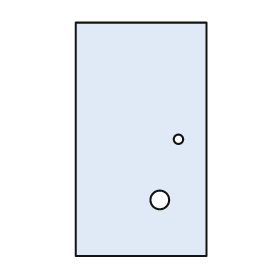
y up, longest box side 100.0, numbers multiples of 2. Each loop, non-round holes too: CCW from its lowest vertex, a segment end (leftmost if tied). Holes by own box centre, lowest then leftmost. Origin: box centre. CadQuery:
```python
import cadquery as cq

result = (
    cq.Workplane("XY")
    .moveTo(-28.0, -50.0)
    .lineTo(28.0, -50.0)
    .lineTo(28.0, 50.0)
    .lineTo(-28.0, 50.0)
    .close()
    .moveTo(8.0, -26.0)
    .circle(4.0)
    .moveTo(16.0, 0.0)
    .circle(2.0)
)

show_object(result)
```